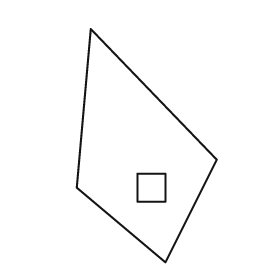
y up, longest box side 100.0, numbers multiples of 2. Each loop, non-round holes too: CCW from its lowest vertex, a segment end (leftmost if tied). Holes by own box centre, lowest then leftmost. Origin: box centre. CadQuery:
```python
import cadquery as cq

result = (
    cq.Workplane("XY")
    .moveTo(8.0, -50.0)
    .lineTo(30.0, -6.0)
    .lineTo(-24.0, 50.0)
    .lineTo(-30.0, -18.0)
    .close()
    .moveTo(-4.0, -24.0)
    .lineTo(8.0, -24.0)
    .lineTo(8.0, -12.0)
    .lineTo(-4.0, -12.0)
    .close()
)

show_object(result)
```